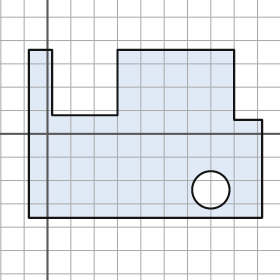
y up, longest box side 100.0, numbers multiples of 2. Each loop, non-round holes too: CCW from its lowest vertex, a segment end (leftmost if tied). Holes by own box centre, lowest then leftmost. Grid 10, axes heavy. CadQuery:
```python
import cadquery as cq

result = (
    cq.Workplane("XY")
    .moveTo(-8.0, -36.0)
    .lineTo(92.0, -36.0)
    .lineTo(92.0, 6.0)
    .lineTo(80.0, 6.0)
    .lineTo(80.0, 36.0)
    .lineTo(30.0, 36.0)
    .lineTo(30.0, 8.0)
    .lineTo(2.0, 8.0)
    .lineTo(2.0, 36.0)
    .lineTo(-8.0, 36.0)
    .close()
    .moveTo(70.0, -24.0)
    .circle(8.0)
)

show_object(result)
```